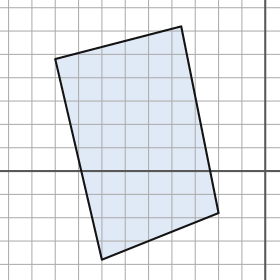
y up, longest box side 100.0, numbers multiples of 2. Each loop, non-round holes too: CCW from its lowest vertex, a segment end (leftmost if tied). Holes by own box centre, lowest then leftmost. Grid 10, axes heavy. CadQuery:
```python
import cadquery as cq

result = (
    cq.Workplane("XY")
    .moveTo(-70.0, -38.0)
    .lineTo(-20.0, -18.0)
    .lineTo(-36.0, 62.0)
    .lineTo(-90.0, 48.0)
    .close()
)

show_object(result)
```